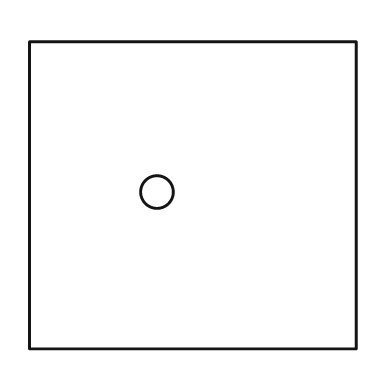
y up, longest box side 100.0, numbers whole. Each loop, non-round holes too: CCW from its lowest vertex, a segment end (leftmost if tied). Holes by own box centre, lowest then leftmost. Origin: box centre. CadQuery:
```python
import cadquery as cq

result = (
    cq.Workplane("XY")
    .moveTo(-50.0, -47.0)
    .lineTo(50.0, -47.0)
    .lineTo(50.0, 47.0)
    .lineTo(-50.0, 47.0)
    .close()
    .moveTo(-11.0, 1.0)
    .circle(5.0)
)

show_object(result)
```